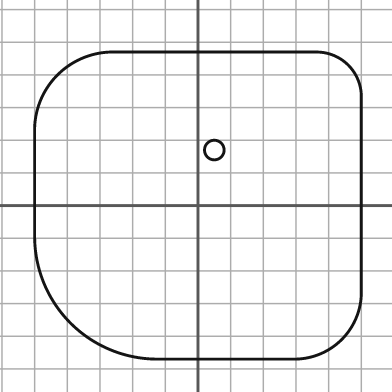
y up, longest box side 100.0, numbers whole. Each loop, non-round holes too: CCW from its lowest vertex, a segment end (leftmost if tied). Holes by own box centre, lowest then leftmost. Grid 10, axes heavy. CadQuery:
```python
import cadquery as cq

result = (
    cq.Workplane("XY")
    .moveTo(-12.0, -47.0)
    .lineTo(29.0, -47.0)
    .threePointArc((44.0, -41.0), (50.0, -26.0))
    .lineTo(50.0, 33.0)
    .threePointArc((46.0, 43.0), (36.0, 47.0))
    .lineTo(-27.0, 47.0)
    .threePointArc((-43.0, 40.0), (-50.0, 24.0))
    .lineTo(-50.0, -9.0)
    .threePointArc((-39.0, -36.0), (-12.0, -47.0))
    .close()
    .moveTo(5.0, 17.0)
    .circle(3.0)
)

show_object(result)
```